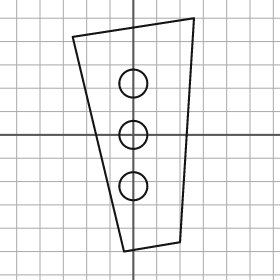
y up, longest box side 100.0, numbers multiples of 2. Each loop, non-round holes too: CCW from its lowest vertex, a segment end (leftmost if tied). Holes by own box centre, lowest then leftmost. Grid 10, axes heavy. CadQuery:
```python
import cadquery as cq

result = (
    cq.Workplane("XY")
    .moveTo(-4.0, -50.0)
    .lineTo(20.0, -46.0)
    .lineTo(26.0, 50.0)
    .lineTo(-26.0, 42.0)
    .close()
    .moveTo(0.0, -22.0)
    .circle(6.0)
    .moveTo(0.0, 0.0)
    .circle(6.0)
    .moveTo(0.0, 22.0)
    .circle(6.0)
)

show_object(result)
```